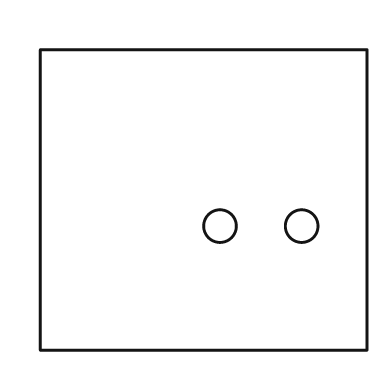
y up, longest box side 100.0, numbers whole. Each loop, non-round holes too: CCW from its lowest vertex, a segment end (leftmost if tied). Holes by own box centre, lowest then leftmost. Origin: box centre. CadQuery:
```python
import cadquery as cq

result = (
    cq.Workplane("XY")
    .moveTo(-50.0, -46.0)
    .lineTo(50.0, -46.0)
    .lineTo(50.0, 46.0)
    .lineTo(-50.0, 46.0)
    .close()
    .moveTo(5.0, -8.0)
    .circle(5.0)
    .moveTo(30.0, -8.0)
    .circle(5.0)
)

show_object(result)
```